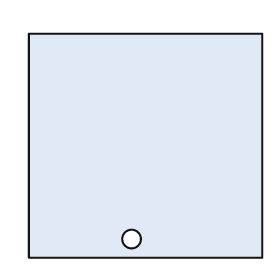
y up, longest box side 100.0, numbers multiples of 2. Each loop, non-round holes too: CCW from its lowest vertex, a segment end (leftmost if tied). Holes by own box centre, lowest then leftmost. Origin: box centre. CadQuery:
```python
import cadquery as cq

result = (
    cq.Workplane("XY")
    .moveTo(-50.0, -48.0)
    .lineTo(50.0, -48.0)
    .lineTo(50.0, 48.0)
    .lineTo(-50.0, 48.0)
    .close()
    .moveTo(-6.0, -40.0)
    .circle(4.0)
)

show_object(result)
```